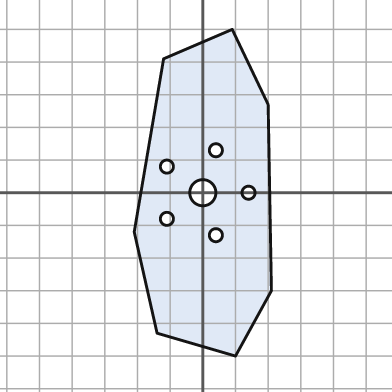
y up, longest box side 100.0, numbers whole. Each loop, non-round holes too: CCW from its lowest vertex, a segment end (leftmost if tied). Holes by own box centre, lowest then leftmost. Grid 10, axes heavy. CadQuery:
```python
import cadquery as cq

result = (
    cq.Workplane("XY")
    .moveTo(10.0, -50.0)
    .lineTo(21.0, -30.0)
    .lineTo(20.0, 27.0)
    .lineTo(9.0, 50.0)
    .lineTo(-12.0, 41.0)
    .lineTo(-21.0, -12.0)
    .lineTo(-14.0, -43.0)
    .close()
    .moveTo(4.0, -13.0)
    .circle(2.0)
    .moveTo(-11.0, -8.0)
    .circle(2.0)
    .moveTo(0.0, 0.0)
    .circle(4.0)
    .moveTo(14.0, 0.0)
    .circle(2.0)
    .moveTo(-11.0, 8.0)
    .circle(2.0)
    .moveTo(4.0, 13.0)
    .circle(2.0)
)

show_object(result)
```